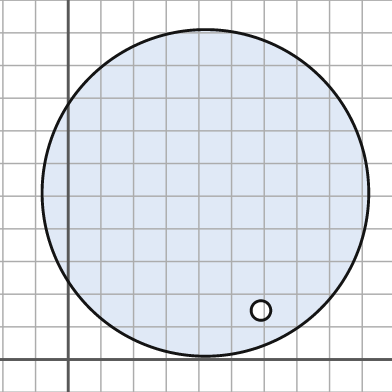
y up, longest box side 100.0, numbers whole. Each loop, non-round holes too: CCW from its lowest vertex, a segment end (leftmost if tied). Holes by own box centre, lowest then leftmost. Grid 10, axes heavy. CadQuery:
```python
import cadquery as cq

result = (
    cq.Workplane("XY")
    .moveTo(42.0, 51.0)
    .circle(50.0)
    .moveTo(59.0, 15.0)
    .circle(3.0)
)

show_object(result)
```